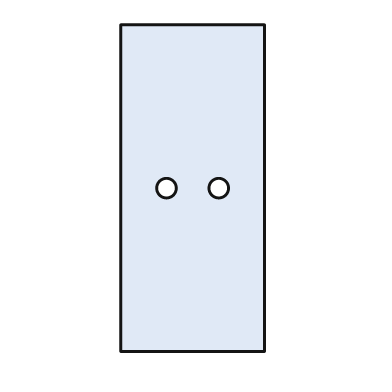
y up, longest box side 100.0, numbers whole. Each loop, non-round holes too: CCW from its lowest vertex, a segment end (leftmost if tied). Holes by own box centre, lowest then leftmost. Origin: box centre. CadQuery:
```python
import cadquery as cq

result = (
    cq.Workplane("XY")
    .moveTo(-22.0, -50.0)
    .lineTo(22.0, -50.0)
    .lineTo(22.0, 50.0)
    .lineTo(-22.0, 50.0)
    .close()
    .moveTo(-8.0, 0.0)
    .circle(3.0)
    .moveTo(8.0, 0.0)
    .circle(3.0)
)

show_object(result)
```